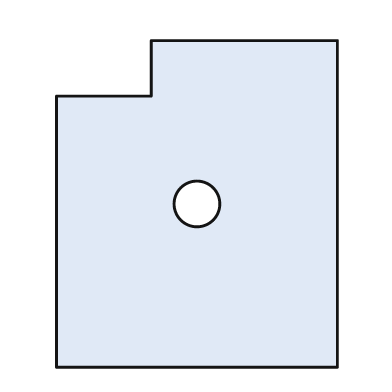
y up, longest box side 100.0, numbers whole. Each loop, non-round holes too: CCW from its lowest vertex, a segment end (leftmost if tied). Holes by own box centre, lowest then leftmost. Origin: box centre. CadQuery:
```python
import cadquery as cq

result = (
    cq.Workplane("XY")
    .moveTo(-43.0, -50.0)
    .lineTo(43.0, -50.0)
    .lineTo(43.0, 50.0)
    .lineTo(-14.0, 50.0)
    .lineTo(-14.0, 33.0)
    .lineTo(-43.0, 33.0)
    .close()
    .moveTo(0.0, 0.0)
    .circle(7.0)
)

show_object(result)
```